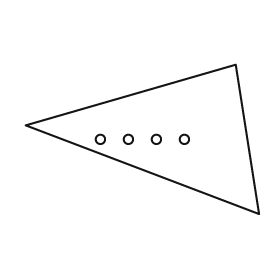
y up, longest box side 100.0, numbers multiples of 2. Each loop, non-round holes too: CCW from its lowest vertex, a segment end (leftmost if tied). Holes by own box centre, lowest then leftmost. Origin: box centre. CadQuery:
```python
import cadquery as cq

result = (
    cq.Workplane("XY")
    .moveTo(50.0, -32.0)
    .lineTo(40.0, 32.0)
    .lineTo(-50.0, 6.0)
    .close()
    .moveTo(-18.0, 0.0)
    .circle(2.0)
    .moveTo(-6.0, 0.0)
    .circle(2.0)
    .moveTo(6.0, 0.0)
    .circle(2.0)
    .moveTo(18.0, 0.0)
    .circle(2.0)
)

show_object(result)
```